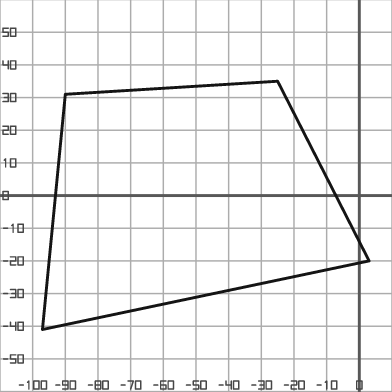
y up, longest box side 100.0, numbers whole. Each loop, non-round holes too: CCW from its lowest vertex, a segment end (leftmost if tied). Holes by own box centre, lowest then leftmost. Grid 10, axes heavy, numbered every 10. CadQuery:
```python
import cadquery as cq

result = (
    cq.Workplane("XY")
    .moveTo(-97.0, -41.0)
    .lineTo(3.0, -20.0)
    .lineTo(-25.0, 35.0)
    .lineTo(-90.0, 31.0)
    .close()
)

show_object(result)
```